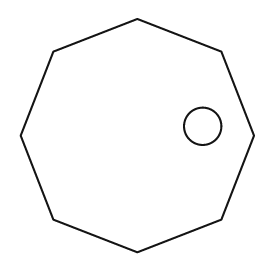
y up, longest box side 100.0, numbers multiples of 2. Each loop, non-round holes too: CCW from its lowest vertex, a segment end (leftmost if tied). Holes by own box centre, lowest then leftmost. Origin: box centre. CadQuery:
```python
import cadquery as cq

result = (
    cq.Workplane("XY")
    .moveTo(0.0, -50.0)
    .lineTo(36.0, -36.0)
    .lineTo(50.0, 0.0)
    .lineTo(36.0, 36.0)
    .lineTo(0.0, 50.0)
    .lineTo(-36.0, 36.0)
    .lineTo(-50.0, 0.0)
    .lineTo(-36.0, -36.0)
    .close()
    .moveTo(28.0, 4.0)
    .circle(8.0)
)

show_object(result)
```